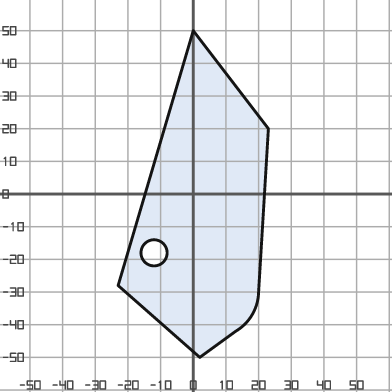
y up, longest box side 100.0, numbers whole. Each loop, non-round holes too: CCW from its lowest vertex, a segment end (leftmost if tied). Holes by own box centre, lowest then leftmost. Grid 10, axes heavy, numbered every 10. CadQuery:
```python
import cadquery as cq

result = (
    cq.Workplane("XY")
    .moveTo(2.0, -50.0)
    .lineTo(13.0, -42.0)
    .threePointArc((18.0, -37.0), (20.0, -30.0))
    .lineTo(23.0, 20.0)
    .lineTo(0.0, 50.0)
    .lineTo(-23.0, -28.0)
    .close()
    .moveTo(-12.0, -18.0)
    .circle(4.0)
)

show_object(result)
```